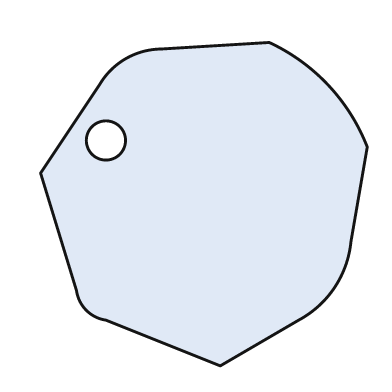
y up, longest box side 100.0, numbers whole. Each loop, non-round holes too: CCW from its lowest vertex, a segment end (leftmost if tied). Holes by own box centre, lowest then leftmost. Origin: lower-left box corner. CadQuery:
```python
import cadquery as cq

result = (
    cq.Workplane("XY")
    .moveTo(55.0, 0.0)
    .lineTo(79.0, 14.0)
    .threePointArc((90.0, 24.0), (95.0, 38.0))
    .lineTo(100.0, 67.0)
    .threePointArc((88.0, 86.0), (70.0, 99.0))
    .lineTo(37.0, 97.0)
    .threePointArc((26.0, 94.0), (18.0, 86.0))
    .lineTo(0.0, 59.0)
    .lineTo(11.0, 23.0)
    .threePointArc((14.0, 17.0), (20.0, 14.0))
    .close()
    .moveTo(20.0, 69.0)
    .circle(6.0)
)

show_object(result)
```